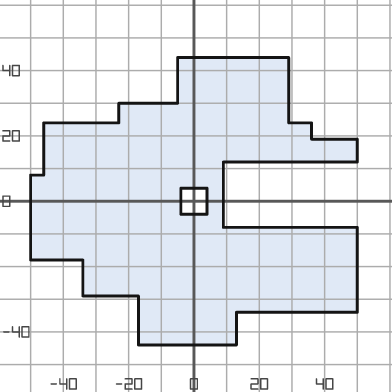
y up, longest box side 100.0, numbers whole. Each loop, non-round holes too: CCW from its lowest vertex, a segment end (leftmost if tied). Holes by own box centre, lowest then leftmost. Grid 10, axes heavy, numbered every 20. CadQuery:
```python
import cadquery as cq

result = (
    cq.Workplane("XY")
    .moveTo(-17.0, -44.0)
    .lineTo(13.0, -44.0)
    .lineTo(13.0, -34.0)
    .lineTo(50.0, -34.0)
    .lineTo(50.0, -8.0)
    .lineTo(9.0, -8.0)
    .lineTo(9.0, 12.0)
    .lineTo(50.0, 12.0)
    .lineTo(50.0, 19.0)
    .lineTo(36.0, 19.0)
    .lineTo(36.0, 24.0)
    .lineTo(29.0, 24.0)
    .lineTo(29.0, 44.0)
    .lineTo(-5.0, 44.0)
    .lineTo(-5.0, 30.0)
    .lineTo(-23.0, 30.0)
    .lineTo(-23.0, 24.0)
    .lineTo(-46.0, 24.0)
    .lineTo(-46.0, 8.0)
    .lineTo(-50.0, 8.0)
    .lineTo(-50.0, -18.0)
    .lineTo(-34.0, -18.0)
    .lineTo(-34.0, -29.0)
    .lineTo(-17.0, -29.0)
    .close()
    .moveTo(-4.0, -4.0)
    .lineTo(4.0, -4.0)
    .lineTo(4.0, 4.0)
    .lineTo(-4.0, 4.0)
    .close()
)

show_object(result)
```